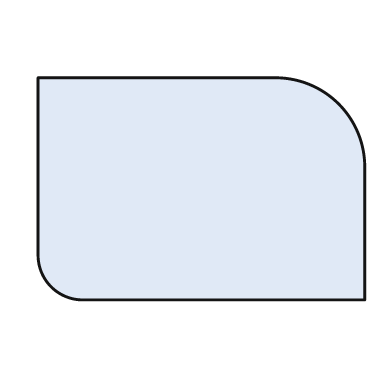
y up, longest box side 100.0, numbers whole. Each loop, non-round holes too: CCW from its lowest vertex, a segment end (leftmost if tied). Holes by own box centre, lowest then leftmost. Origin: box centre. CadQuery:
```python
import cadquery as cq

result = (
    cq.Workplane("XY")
    .moveTo(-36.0, -34.0)
    .lineTo(50.0, -34.0)
    .lineTo(50.0, 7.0)
    .threePointArc((42.0, 26.0), (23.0, 34.0))
    .lineTo(-50.0, 34.0)
    .lineTo(-50.0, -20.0)
    .threePointArc((-46.0, -30.0), (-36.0, -34.0))
    .close()
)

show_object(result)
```